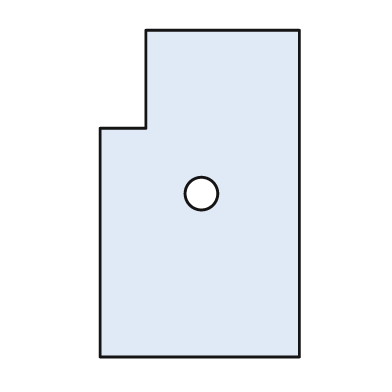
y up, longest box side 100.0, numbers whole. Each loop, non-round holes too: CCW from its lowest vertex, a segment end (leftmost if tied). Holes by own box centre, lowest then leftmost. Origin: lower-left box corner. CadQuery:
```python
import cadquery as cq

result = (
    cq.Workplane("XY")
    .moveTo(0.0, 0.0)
    .lineTo(61.0, 0.0)
    .lineTo(61.0, 100.0)
    .lineTo(14.0, 100.0)
    .lineTo(14.0, 70.0)
    .lineTo(0.0, 70.0)
    .close()
    .moveTo(31.0, 50.0)
    .circle(5.0)
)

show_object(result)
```